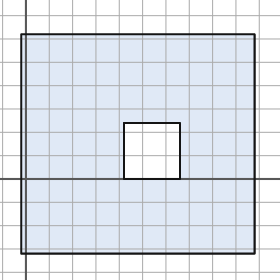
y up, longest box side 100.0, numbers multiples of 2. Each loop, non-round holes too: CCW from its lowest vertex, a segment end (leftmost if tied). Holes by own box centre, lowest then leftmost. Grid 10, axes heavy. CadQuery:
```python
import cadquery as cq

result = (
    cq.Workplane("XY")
    .moveTo(-2.0, -32.0)
    .lineTo(98.0, -32.0)
    .lineTo(98.0, 62.0)
    .lineTo(-2.0, 62.0)
    .close()
    .moveTo(42.0, 0.0)
    .lineTo(66.0, 0.0)
    .lineTo(66.0, 24.0)
    .lineTo(42.0, 24.0)
    .close()
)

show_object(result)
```